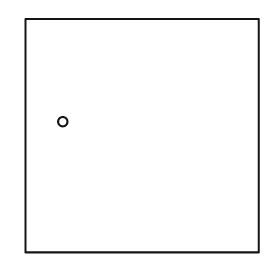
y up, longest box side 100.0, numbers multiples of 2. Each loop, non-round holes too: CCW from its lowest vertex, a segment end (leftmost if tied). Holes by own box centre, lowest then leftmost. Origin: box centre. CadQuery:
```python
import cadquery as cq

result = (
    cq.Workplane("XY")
    .moveTo(-50.0, -50.0)
    .lineTo(50.0, -50.0)
    .lineTo(50.0, 50.0)
    .lineTo(-50.0, 50.0)
    .close()
    .moveTo(-34.0, 6.0)
    .circle(2.0)
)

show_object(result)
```